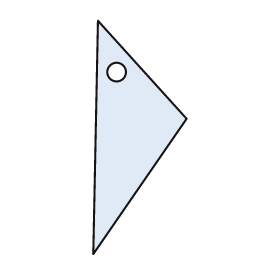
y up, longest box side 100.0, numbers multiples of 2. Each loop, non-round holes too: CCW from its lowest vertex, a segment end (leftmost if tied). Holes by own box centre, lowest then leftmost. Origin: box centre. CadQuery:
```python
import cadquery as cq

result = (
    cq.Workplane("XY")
    .moveTo(-20.0, -50.0)
    .lineTo(20.0, 8.0)
    .lineTo(-18.0, 50.0)
    .close()
    .moveTo(-10.0, 28.0)
    .circle(4.0)
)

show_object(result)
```